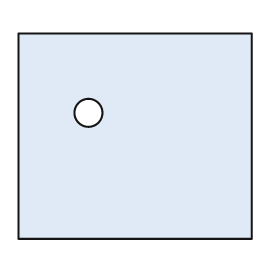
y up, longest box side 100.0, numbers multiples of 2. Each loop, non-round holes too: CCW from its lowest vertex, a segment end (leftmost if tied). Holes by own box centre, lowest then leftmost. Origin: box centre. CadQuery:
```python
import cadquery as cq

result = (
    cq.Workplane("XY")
    .moveTo(-50.0, -44.0)
    .lineTo(50.0, -44.0)
    .lineTo(50.0, 44.0)
    .lineTo(-50.0, 44.0)
    .close()
    .moveTo(-20.0, 10.0)
    .circle(6.0)
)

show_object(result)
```